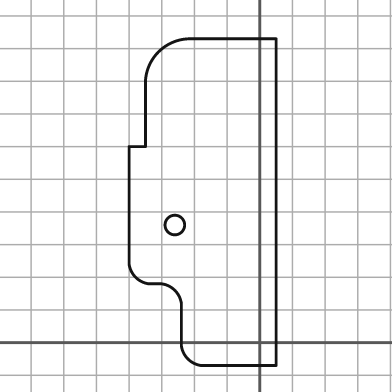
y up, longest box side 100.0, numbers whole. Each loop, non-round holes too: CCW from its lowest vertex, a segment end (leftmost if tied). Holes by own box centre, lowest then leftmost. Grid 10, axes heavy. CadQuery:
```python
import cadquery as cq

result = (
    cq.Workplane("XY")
    .moveTo(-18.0, -7.0)
    .lineTo(5.0, -7.0)
    .lineTo(5.0, 93.0)
    .lineTo(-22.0, 93.0)
    .threePointArc((-31.0, 89.0), (-35.0, 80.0))
    .lineTo(-35.0, 60.0)
    .lineTo(-40.0, 60.0)
    .lineTo(-40.0, 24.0)
    .threePointArc((-38.0, 20.0), (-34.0, 18.0))
    .lineTo(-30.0, 18.0)
    .threePointArc((-26.0, 16.0), (-24.0, 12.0))
    .lineTo(-24.0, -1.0)
    .threePointArc((-22.0, -5.0), (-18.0, -7.0))
    .close()
    .moveTo(-26.0, 36.0)
    .circle(3.0)
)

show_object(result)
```